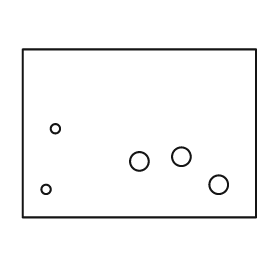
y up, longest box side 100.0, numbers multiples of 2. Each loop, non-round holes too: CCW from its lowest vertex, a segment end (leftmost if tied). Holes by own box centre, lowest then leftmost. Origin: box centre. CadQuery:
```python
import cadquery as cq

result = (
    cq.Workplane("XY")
    .moveTo(-50.0, -36.0)
    .lineTo(50.0, -36.0)
    .lineTo(50.0, 36.0)
    .lineTo(-50.0, 36.0)
    .close()
    .moveTo(-40.0, -24.0)
    .circle(2.0)
    .moveTo(34.0, -22.0)
    .circle(4.0)
    .moveTo(0.0, -12.0)
    .circle(4.0)
    .moveTo(18.0, -10.0)
    .circle(4.0)
    .moveTo(-36.0, 2.0)
    .circle(2.0)
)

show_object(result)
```